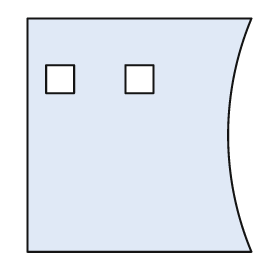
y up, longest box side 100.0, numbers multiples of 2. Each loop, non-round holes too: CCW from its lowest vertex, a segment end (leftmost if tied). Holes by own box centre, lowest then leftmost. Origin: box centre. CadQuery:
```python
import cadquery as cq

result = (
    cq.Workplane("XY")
    .moveTo(-48.0, -50.0)
    .lineTo(48.0, -50.0)
    .threePointArc((38.0, 0.0), (48.0, 50.0))
    .lineTo(-48.0, 50.0)
    .close()
    .moveTo(-40.0, 18.0)
    .lineTo(-28.0, 18.0)
    .lineTo(-28.0, 30.0)
    .lineTo(-40.0, 30.0)
    .close()
    .moveTo(-6.0, 18.0)
    .lineTo(6.0, 18.0)
    .lineTo(6.0, 30.0)
    .lineTo(-6.0, 30.0)
    .close()
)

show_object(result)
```